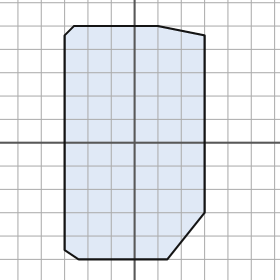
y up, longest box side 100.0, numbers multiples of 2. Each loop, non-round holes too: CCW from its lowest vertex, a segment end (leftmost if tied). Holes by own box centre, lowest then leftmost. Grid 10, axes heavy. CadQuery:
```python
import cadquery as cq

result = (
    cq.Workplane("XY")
    .moveTo(-24.0, -50.0)
    .lineTo(14.0, -50.0)
    .lineTo(30.0, -30.0)
    .lineTo(30.0, 46.0)
    .lineTo(10.0, 50.0)
    .lineTo(-26.0, 50.0)
    .lineTo(-30.0, 46.0)
    .lineTo(-30.0, -46.0)
    .close()
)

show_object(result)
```